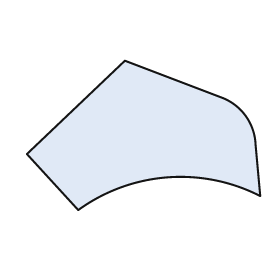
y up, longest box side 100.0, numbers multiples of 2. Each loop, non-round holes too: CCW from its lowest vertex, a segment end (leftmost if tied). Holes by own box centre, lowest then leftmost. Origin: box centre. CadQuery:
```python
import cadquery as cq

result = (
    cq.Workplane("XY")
    .moveTo(-28.0, -32.0)
    .threePointArc((10.0, -18.0), (50.0, -26.0))
    .lineTo(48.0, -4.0)
    .threePointArc((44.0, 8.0), (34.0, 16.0))
    .lineTo(-8.0, 32.0)
    .lineTo(-50.0, -8.0)
    .close()
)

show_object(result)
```